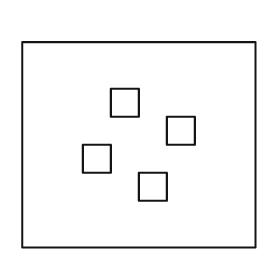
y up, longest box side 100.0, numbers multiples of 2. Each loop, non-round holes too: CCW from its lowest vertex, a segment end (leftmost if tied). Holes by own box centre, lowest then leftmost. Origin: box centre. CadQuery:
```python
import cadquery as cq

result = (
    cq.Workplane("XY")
    .moveTo(-50.0, -44.0)
    .lineTo(50.0, -44.0)
    .lineTo(50.0, 44.0)
    .lineTo(-50.0, 44.0)
    .close()
    .moveTo(0.0, -24.0)
    .lineTo(12.0, -24.0)
    .lineTo(12.0, -12.0)
    .lineTo(0.0, -12.0)
    .close()
    .moveTo(-24.0, -12.0)
    .lineTo(-12.0, -12.0)
    .lineTo(-12.0, 0.0)
    .lineTo(-24.0, 0.0)
    .close()
    .moveTo(12.0, 0.0)
    .lineTo(24.0, 0.0)
    .lineTo(24.0, 12.0)
    .lineTo(12.0, 12.0)
    .close()
    .moveTo(-12.0, 12.0)
    .lineTo(0.0, 12.0)
    .lineTo(0.0, 24.0)
    .lineTo(-12.0, 24.0)
    .close()
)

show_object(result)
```